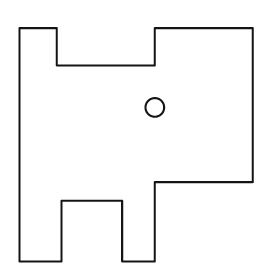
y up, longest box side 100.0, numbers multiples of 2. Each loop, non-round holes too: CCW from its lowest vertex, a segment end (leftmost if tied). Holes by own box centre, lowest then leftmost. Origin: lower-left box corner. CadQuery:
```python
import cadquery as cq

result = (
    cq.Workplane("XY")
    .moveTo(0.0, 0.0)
    .lineTo(18.0, 0.0)
    .lineTo(18.0, 26.0)
    .lineTo(44.0, 26.0)
    .lineTo(44.0, 0.0)
    .lineTo(58.0, 0.0)
    .lineTo(58.0, 34.0)
    .lineTo(100.0, 34.0)
    .lineTo(100.0, 100.0)
    .lineTo(58.0, 100.0)
    .lineTo(58.0, 84.0)
    .lineTo(16.0, 84.0)
    .lineTo(16.0, 100.0)
    .lineTo(0.0, 100.0)
    .close()
    .moveTo(58.0, 66.0)
    .circle(4.0)
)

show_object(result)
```